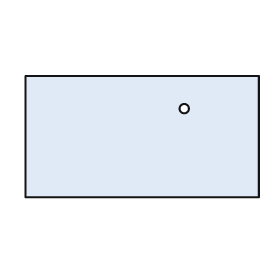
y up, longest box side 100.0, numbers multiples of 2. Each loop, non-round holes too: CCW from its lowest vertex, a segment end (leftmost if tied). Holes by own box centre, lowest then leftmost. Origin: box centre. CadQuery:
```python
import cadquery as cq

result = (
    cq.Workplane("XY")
    .moveTo(-50.0, -26.0)
    .lineTo(50.0, -26.0)
    .lineTo(50.0, 26.0)
    .lineTo(-50.0, 26.0)
    .close()
    .moveTo(18.0, 12.0)
    .circle(2.0)
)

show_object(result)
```